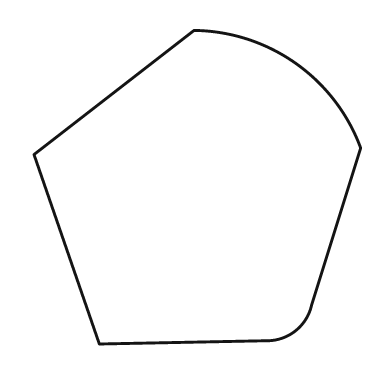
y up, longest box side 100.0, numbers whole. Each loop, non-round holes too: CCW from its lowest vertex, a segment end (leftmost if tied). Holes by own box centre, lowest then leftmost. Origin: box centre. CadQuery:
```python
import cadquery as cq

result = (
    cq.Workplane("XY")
    .moveTo(-30.0, -48.0)
    .lineTo(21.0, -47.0)
    .threePointArc((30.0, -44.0), (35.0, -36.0))
    .lineTo(50.0, 12.0)
    .threePointArc((30.0, 38.0), (-1.0, 48.0))
    .lineTo(-50.0, 10.0)
    .close()
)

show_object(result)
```